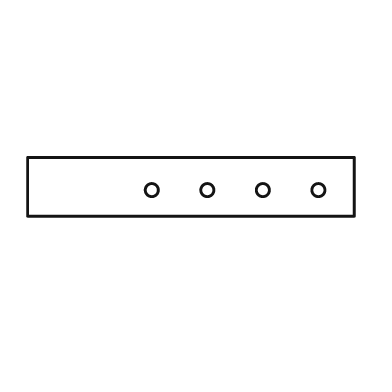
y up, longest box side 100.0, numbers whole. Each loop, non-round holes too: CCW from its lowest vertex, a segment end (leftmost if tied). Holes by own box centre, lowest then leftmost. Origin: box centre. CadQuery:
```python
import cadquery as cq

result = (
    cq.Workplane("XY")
    .moveTo(-50.0, -9.0)
    .lineTo(50.0, -9.0)
    .lineTo(50.0, 9.0)
    .lineTo(-50.0, 9.0)
    .close()
    .moveTo(-12.0, -1.0)
    .circle(2.0)
    .moveTo(5.0, -1.0)
    .circle(2.0)
    .moveTo(22.0, -1.0)
    .circle(2.0)
    .moveTo(39.0, -1.0)
    .circle(2.0)
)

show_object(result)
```